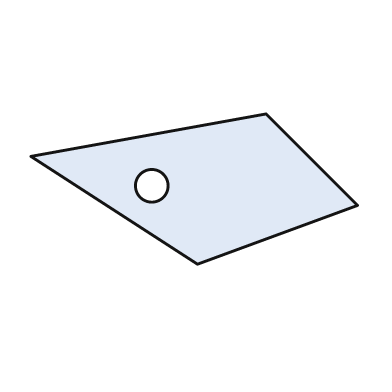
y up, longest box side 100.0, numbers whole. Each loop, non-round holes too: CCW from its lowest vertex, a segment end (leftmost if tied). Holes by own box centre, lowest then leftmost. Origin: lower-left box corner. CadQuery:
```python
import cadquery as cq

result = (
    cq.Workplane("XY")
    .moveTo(51.0, 0.0)
    .lineTo(100.0, 18.0)
    .lineTo(72.0, 46.0)
    .lineTo(0.0, 33.0)
    .close()
    .moveTo(37.0, 24.0)
    .circle(5.0)
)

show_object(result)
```